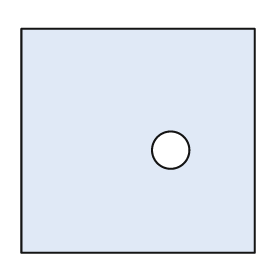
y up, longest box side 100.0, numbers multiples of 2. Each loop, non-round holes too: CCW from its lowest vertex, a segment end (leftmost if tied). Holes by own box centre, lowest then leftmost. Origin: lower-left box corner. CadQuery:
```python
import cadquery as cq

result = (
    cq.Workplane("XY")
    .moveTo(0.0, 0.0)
    .lineTo(100.0, 0.0)
    .lineTo(100.0, 96.0)
    .lineTo(0.0, 96.0)
    .close()
    .moveTo(64.0, 44.0)
    .circle(8.0)
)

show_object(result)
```